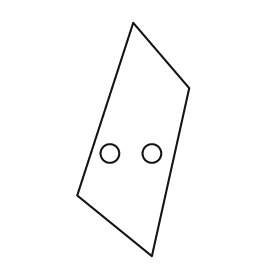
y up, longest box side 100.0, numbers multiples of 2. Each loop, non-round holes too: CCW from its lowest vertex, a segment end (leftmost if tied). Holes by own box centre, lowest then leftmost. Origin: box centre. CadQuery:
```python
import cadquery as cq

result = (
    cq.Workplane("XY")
    .moveTo(8.0, -50.0)
    .lineTo(24.0, 22.0)
    .lineTo(0.0, 50.0)
    .lineTo(-24.0, -24.0)
    .close()
    .moveTo(-10.0, -6.0)
    .circle(4.0)
    .moveTo(8.0, -6.0)
    .circle(4.0)
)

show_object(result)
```